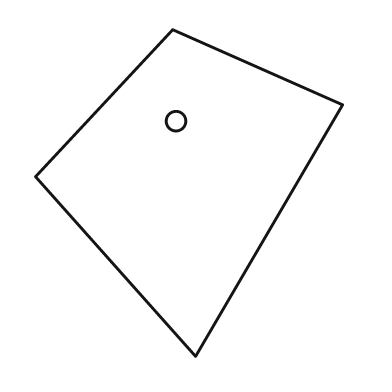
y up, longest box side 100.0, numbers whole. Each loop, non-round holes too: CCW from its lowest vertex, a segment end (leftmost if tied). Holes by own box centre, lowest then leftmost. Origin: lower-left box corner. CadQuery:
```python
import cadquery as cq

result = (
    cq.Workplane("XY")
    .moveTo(49.0, 0.0)
    .lineTo(94.0, 77.0)
    .lineTo(42.0, 100.0)
    .lineTo(0.0, 55.0)
    .close()
    .moveTo(43.0, 72.0)
    .circle(3.0)
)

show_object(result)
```